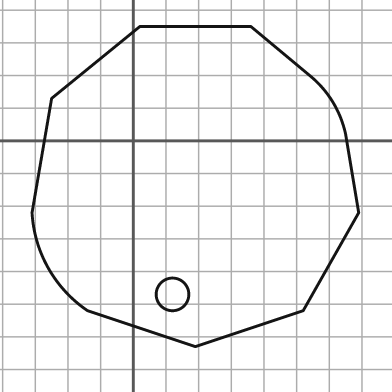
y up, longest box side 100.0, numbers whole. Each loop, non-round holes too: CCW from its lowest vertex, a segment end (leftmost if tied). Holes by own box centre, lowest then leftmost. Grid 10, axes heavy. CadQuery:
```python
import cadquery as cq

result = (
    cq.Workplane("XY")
    .moveTo(19.0, -63.0)
    .lineTo(52.0, -52.0)
    .lineTo(69.0, -22.0)
    .lineTo(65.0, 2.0)
    .threePointArc((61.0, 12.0), (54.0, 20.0))
    .lineTo(36.0, 35.0)
    .lineTo(2.0, 35.0)
    .lineTo(-25.0, 13.0)
    .lineTo(-31.0, -22.0)
    .threePointArc((-26.0, -39.0), (-14.0, -52.0))
    .close()
    .moveTo(12.0, -47.0)
    .circle(5.0)
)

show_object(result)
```